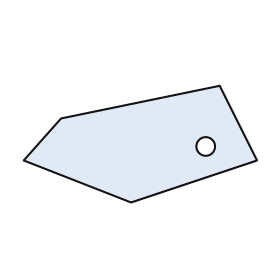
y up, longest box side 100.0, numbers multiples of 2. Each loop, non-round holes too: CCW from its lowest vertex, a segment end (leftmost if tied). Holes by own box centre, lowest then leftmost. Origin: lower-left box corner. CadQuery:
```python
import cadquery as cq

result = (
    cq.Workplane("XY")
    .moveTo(46.0, 0.0)
    .lineTo(100.0, 18.0)
    .lineTo(84.0, 50.0)
    .lineTo(16.0, 36.0)
    .lineTo(0.0, 18.0)
    .close()
    .moveTo(78.0, 24.0)
    .circle(4.0)
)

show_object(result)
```